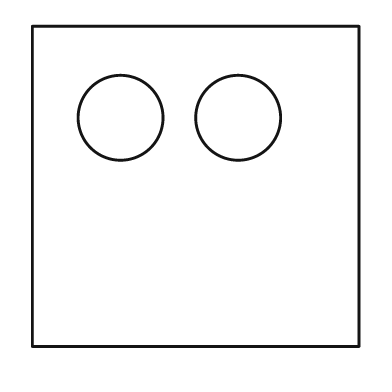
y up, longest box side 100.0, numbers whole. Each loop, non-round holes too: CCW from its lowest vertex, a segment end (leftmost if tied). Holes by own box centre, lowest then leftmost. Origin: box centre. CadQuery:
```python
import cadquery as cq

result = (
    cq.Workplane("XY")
    .moveTo(-50.0, -49.0)
    .lineTo(50.0, -49.0)
    .lineTo(50.0, 49.0)
    .lineTo(-50.0, 49.0)
    .close()
    .moveTo(-23.0, 21.0)
    .circle(13.0)
    .moveTo(13.0, 21.0)
    .circle(13.0)
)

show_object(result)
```